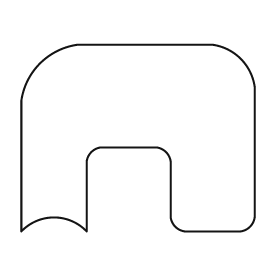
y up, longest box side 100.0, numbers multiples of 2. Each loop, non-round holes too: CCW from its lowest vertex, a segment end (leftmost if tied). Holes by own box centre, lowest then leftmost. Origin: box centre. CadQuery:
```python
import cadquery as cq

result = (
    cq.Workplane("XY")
    .moveTo(-50.0, -40.0)
    .threePointArc((-36.0, -34.0), (-22.0, -40.0))
    .lineTo(-22.0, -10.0)
    .threePointArc((-20.0, -6.0), (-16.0, -4.0))
    .lineTo(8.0, -4.0)
    .threePointArc((12.0, -6.0), (14.0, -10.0))
    .lineTo(14.0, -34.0)
    .threePointArc((16.0, -38.0), (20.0, -40.0))
    .lineTo(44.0, -40.0)
    .threePointArc((48.0, -38.0), (50.0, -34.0))
    .lineTo(50.0, 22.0)
    .threePointArc((44.0, 34.0), (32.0, 40.0))
    .lineTo(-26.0, 40.0)
    .threePointArc((-42.0, 32.0), (-50.0, 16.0))
    .close()
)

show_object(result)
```